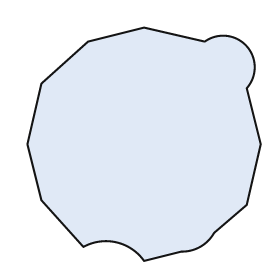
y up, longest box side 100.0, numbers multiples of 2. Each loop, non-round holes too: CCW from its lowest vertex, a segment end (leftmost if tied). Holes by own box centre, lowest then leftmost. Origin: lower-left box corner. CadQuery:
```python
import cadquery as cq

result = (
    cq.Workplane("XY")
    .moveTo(50.0, 0.0)
    .lineTo(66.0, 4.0)
    .threePointArc((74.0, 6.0), (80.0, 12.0))
    .lineTo(94.0, 24.0)
    .lineTo(100.0, 50.0)
    .lineTo(94.0, 74.0)
    .threePointArc((94.0, 92.0), (76.0, 94.0))
    .lineTo(50.0, 100.0)
    .lineTo(26.0, 94.0)
    .lineTo(6.0, 76.0)
    .lineTo(0.0, 50.0)
    .lineTo(6.0, 26.0)
    .lineTo(24.0, 6.0)
    .threePointArc((38.0, 8.0), (50.0, 0.0))
    .close()
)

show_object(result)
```